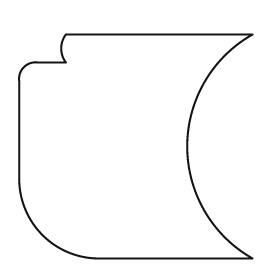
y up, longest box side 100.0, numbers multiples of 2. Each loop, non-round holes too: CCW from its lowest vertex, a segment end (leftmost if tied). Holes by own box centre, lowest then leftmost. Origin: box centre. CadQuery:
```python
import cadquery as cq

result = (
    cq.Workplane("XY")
    .moveTo(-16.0, -48.0)
    .lineTo(50.0, -48.0)
    .threePointArc((22.0, 0.0), (50.0, 48.0))
    .lineTo(-30.0, 48.0)
    .threePointArc((-32.0, 42.0), (-30.0, 36.0))
    .lineTo(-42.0, 36.0)
    .threePointArc((-48.0, 34.0), (-50.0, 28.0))
    .lineTo(-50.0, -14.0)
    .threePointArc((-40.0, -38.0), (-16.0, -48.0))
    .close()
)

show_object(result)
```